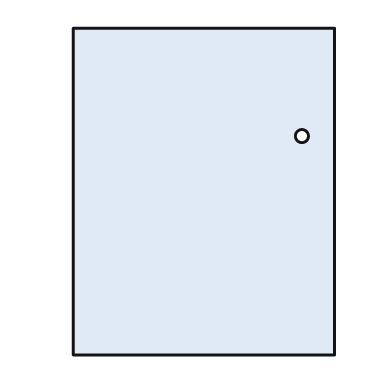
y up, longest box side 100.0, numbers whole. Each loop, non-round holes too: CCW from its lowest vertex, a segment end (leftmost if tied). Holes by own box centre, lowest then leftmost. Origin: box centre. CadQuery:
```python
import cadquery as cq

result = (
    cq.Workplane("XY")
    .moveTo(-40.0, -50.0)
    .lineTo(40.0, -50.0)
    .lineTo(40.0, 50.0)
    .lineTo(-40.0, 50.0)
    .close()
    .moveTo(30.0, 17.0)
    .circle(2.0)
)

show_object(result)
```